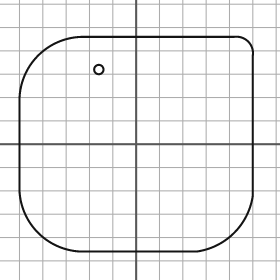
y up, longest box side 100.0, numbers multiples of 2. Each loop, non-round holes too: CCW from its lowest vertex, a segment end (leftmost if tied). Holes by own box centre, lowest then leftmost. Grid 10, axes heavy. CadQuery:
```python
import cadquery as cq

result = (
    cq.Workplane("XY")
    .moveTo(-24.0, -46.0)
    .lineTo(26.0, -46.0)
    .threePointArc((42.0, -38.0), (50.0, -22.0))
    .lineTo(50.0, 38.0)
    .threePointArc((48.0, 44.0), (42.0, 46.0))
    .lineTo(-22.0, 46.0)
    .threePointArc((-42.0, 38.0), (-50.0, 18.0))
    .lineTo(-50.0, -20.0)
    .threePointArc((-42.0, -38.0), (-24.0, -46.0))
    .close()
    .moveTo(-16.0, 32.0)
    .circle(2.0)
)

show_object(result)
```